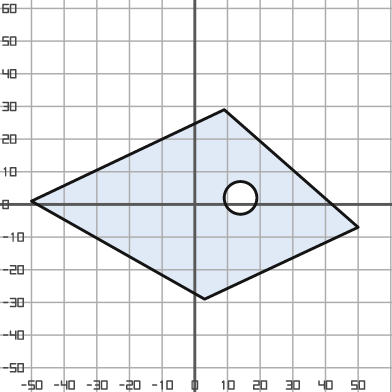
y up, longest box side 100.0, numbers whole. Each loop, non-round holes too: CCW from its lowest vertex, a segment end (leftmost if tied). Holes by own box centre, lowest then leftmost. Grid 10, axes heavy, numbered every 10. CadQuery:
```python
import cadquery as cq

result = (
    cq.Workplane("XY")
    .moveTo(3.0, -29.0)
    .lineTo(50.0, -7.0)
    .lineTo(9.0, 29.0)
    .lineTo(-50.0, 1.0)
    .close()
    .moveTo(14.0, 2.0)
    .circle(5.0)
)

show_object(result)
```